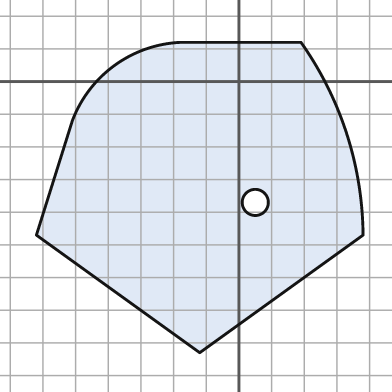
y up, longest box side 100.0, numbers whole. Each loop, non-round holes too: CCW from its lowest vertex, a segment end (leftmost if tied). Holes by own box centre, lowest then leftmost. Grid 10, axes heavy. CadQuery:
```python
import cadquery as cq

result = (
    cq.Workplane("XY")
    .moveTo(-12.0, -83.0)
    .lineTo(38.0, -47.0)
    .threePointArc((33.0, -16.0), (19.0, 12.0))
    .lineTo(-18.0, 12.0)
    .threePointArc((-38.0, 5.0), (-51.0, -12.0))
    .lineTo(-62.0, -47.0)
    .close()
    .moveTo(5.0, -37.0)
    .circle(4.0)
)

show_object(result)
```